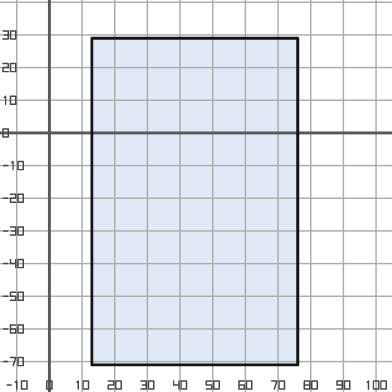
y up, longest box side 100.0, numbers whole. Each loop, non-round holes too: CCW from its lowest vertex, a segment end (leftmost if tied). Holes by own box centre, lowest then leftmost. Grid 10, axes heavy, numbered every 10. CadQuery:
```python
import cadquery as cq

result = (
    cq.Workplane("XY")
    .moveTo(13.0, -71.0)
    .lineTo(76.0, -71.0)
    .lineTo(76.0, 29.0)
    .lineTo(13.0, 29.0)
    .close()
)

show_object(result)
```